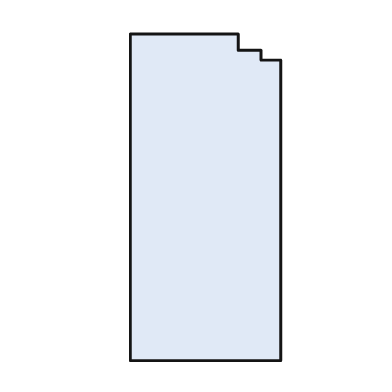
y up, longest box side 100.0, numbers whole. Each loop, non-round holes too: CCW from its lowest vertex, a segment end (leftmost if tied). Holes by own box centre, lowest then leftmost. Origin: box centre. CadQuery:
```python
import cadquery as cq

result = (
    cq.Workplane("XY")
    .moveTo(-23.0, -50.0)
    .lineTo(23.0, -50.0)
    .lineTo(23.0, 42.0)
    .lineTo(17.0, 42.0)
    .lineTo(17.0, 45.0)
    .lineTo(10.0, 45.0)
    .lineTo(10.0, 50.0)
    .lineTo(-23.0, 50.0)
    .close()
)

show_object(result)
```